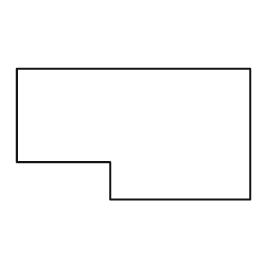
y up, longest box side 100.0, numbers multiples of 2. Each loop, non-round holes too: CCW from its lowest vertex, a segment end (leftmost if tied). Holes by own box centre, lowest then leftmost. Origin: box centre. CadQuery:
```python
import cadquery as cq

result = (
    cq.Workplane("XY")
    .moveTo(-10.0, -28.0)
    .lineTo(50.0, -28.0)
    .lineTo(50.0, 28.0)
    .lineTo(-50.0, 28.0)
    .lineTo(-50.0, -12.0)
    .lineTo(-10.0, -12.0)
    .close()
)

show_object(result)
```